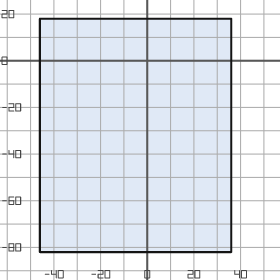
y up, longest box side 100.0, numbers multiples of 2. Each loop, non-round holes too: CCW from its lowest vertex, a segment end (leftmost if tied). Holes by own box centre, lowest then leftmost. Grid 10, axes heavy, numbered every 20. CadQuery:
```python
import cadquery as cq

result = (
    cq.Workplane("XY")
    .moveTo(-46.0, -82.0)
    .lineTo(36.0, -82.0)
    .lineTo(36.0, 18.0)
    .lineTo(-46.0, 18.0)
    .close()
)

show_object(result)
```